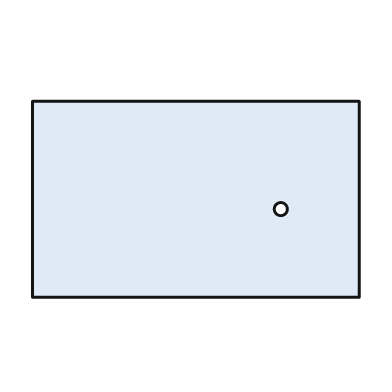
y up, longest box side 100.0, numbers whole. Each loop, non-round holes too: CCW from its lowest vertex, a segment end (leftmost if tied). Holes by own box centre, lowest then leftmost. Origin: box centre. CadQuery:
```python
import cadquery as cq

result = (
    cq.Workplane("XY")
    .moveTo(-50.0, -30.0)
    .lineTo(50.0, -30.0)
    .lineTo(50.0, 30.0)
    .lineTo(-50.0, 30.0)
    .close()
    .moveTo(26.0, -3.0)
    .circle(2.0)
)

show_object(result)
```